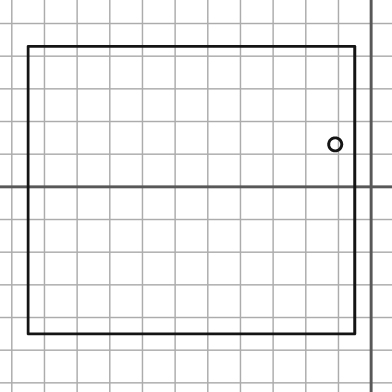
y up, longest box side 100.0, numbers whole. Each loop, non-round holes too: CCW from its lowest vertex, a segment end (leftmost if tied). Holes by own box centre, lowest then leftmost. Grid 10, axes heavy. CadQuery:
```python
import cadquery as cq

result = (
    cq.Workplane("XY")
    .moveTo(-105.0, -45.0)
    .lineTo(-5.0, -45.0)
    .lineTo(-5.0, 43.0)
    .lineTo(-105.0, 43.0)
    .close()
    .moveTo(-11.0, 13.0)
    .circle(2.0)
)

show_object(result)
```